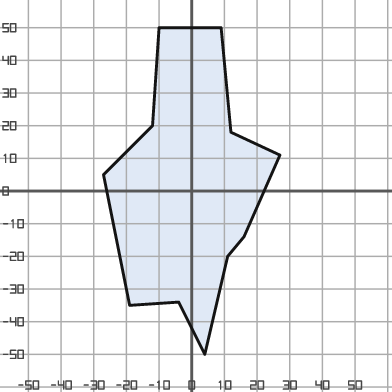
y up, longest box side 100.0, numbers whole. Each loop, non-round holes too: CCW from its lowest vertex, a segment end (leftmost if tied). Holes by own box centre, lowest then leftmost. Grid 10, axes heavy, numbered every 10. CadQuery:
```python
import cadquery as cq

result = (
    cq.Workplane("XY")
    .moveTo(4.0, -50.0)
    .lineTo(11.0, -20.0)
    .lineTo(16.0, -14.0)
    .lineTo(27.0, 11.0)
    .lineTo(12.0, 18.0)
    .lineTo(9.0, 50.0)
    .lineTo(-10.0, 50.0)
    .lineTo(-12.0, 20.0)
    .lineTo(-27.0, 5.0)
    .lineTo(-19.0, -35.0)
    .lineTo(-4.0, -34.0)
    .close()
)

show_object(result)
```